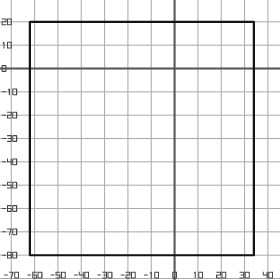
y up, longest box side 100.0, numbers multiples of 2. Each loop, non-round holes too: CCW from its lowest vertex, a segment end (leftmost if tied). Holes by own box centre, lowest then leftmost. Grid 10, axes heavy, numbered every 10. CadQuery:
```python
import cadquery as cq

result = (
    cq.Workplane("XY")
    .moveTo(-62.0, -80.0)
    .lineTo(34.0, -80.0)
    .lineTo(34.0, 20.0)
    .lineTo(-62.0, 20.0)
    .close()
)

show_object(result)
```